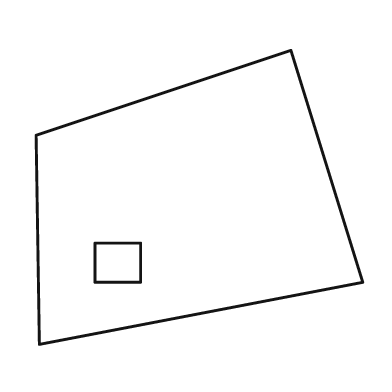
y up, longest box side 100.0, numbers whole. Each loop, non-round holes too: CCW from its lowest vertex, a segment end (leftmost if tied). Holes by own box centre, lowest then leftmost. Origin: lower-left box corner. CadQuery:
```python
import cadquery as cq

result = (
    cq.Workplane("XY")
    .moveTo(1.0, 0.0)
    .lineTo(100.0, 19.0)
    .lineTo(78.0, 90.0)
    .lineTo(0.0, 64.0)
    .close()
    .moveTo(18.0, 19.0)
    .lineTo(32.0, 19.0)
    .lineTo(32.0, 31.0)
    .lineTo(18.0, 31.0)
    .close()
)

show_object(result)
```